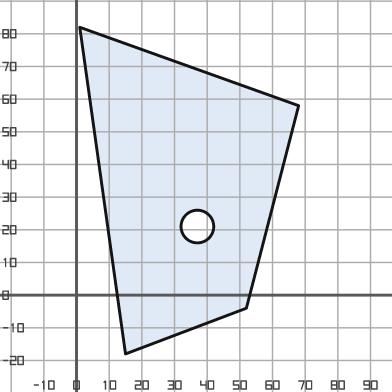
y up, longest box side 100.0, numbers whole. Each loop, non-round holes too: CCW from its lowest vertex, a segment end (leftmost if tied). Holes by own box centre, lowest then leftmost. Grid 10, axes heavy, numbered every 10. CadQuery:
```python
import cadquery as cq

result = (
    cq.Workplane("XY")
    .moveTo(15.0, -18.0)
    .lineTo(52.0, -4.0)
    .lineTo(68.0, 58.0)
    .lineTo(1.0, 82.0)
    .close()
    .moveTo(37.0, 21.0)
    .circle(5.0)
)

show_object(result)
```